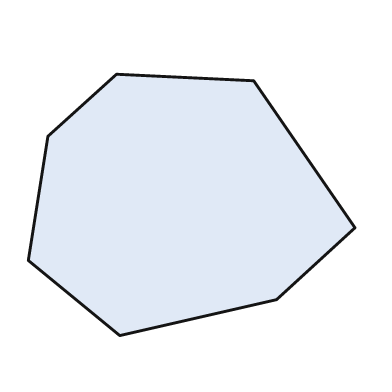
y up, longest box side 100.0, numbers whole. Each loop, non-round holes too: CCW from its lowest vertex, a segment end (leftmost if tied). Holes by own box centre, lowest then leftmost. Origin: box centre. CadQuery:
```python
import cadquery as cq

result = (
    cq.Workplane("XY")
    .moveTo(-22.0, -40.0)
    .lineTo(26.0, -29.0)
    .lineTo(50.0, -7.0)
    .lineTo(19.0, 38.0)
    .lineTo(-23.0, 40.0)
    .lineTo(-44.0, 21.0)
    .lineTo(-50.0, -17.0)
    .close()
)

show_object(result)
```